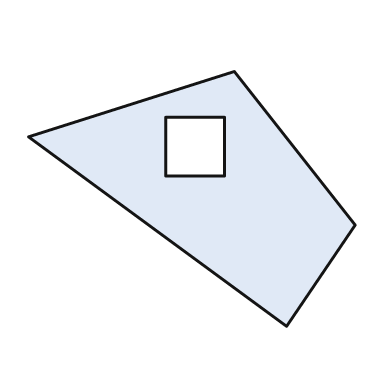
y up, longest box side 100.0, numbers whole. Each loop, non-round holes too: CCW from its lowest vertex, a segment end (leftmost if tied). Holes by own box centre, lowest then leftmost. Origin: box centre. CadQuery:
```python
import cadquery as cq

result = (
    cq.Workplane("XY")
    .moveTo(29.0, -39.0)
    .lineTo(50.0, -8.0)
    .lineTo(13.0, 39.0)
    .lineTo(-50.0, 19.0)
    .close()
    .moveTo(-8.0, 7.0)
    .lineTo(10.0, 7.0)
    .lineTo(10.0, 25.0)
    .lineTo(-8.0, 25.0)
    .close()
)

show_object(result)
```